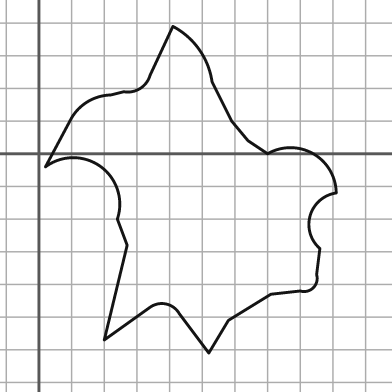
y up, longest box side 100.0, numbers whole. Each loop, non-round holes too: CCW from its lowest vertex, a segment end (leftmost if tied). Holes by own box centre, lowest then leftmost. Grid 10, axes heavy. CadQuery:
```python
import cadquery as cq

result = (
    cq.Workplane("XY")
    .moveTo(52.0, -61.0)
    .lineTo(58.0, -51.0)
    .lineTo(71.0, -43.0)
    .lineTo(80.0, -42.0)
    .threePointArc((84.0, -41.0), (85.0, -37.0))
    .lineTo(86.0, -29.0)
    .threePointArc((83.0, -19.0), (91.0, -12.0))
    .threePointArc((84.0, 0.0), (70.0, 0.0))
    .lineTo(64.0, 4.0)
    .lineTo(59.0, 10.0)
    .lineTo(53.0, 22.0)
    .threePointArc((49.0, 32.0), (41.0, 39.0))
    .lineTo(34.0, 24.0)
    .threePointArc((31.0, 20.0), (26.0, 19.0))
    .lineTo(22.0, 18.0)
    .threePointArc((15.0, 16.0), (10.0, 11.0))
    .lineTo(2.0, -4.0)
    .threePointArc((19.0, -4.0), (24.0, -20.0))
    .lineTo(27.0, -28.0)
    .lineTo(20.0, -57.0)
    .lineTo(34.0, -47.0)
    .threePointArc((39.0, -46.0), (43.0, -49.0))
    .close()
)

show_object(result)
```